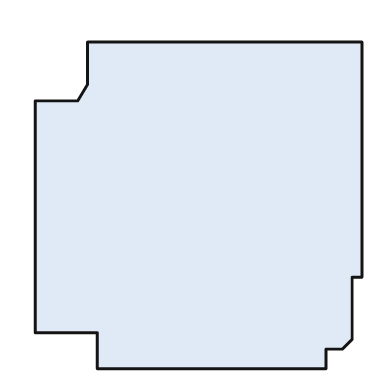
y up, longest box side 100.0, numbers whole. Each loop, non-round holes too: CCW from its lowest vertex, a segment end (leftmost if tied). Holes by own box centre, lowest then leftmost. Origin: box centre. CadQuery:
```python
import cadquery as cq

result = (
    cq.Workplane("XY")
    .moveTo(-31.0, -50.0)
    .lineTo(39.0, -50.0)
    .lineTo(39.0, -44.0)
    .lineTo(44.0, -44.0)
    .lineTo(47.0, -41.0)
    .lineTo(47.0, -22.0)
    .lineTo(50.0, -22.0)
    .lineTo(50.0, 50.0)
    .lineTo(-34.0, 50.0)
    .lineTo(-34.0, 37.0)
    .lineTo(-37.0, 32.0)
    .lineTo(-50.0, 32.0)
    .lineTo(-50.0, -39.0)
    .lineTo(-31.0, -39.0)
    .close()
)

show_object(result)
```